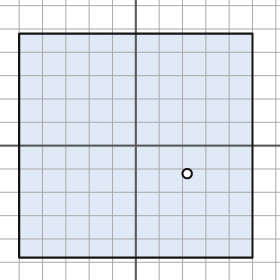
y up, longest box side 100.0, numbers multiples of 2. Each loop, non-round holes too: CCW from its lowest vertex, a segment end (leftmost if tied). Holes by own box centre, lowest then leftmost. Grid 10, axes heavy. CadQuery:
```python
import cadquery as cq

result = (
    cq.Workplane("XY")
    .moveTo(-50.0, -48.0)
    .lineTo(50.0, -48.0)
    .lineTo(50.0, 48.0)
    .lineTo(-50.0, 48.0)
    .close()
    .moveTo(22.0, -12.0)
    .circle(2.0)
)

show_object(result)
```